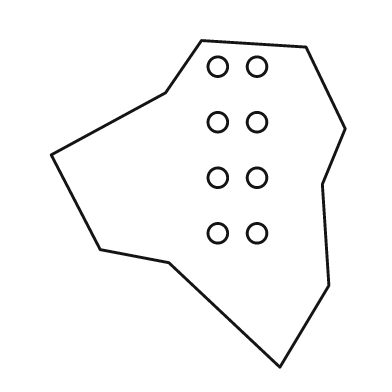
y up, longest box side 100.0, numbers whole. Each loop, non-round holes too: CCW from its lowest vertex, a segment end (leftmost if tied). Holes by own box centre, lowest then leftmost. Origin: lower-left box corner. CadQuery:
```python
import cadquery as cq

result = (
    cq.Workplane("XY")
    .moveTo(70.0, 0.0)
    .lineTo(85.0, 25.0)
    .lineTo(83.0, 56.0)
    .lineTo(90.0, 73.0)
    .lineTo(78.0, 98.0)
    .lineTo(46.0, 100.0)
    .lineTo(35.0, 84.0)
    .lineTo(0.0, 65.0)
    .lineTo(15.0, 36.0)
    .lineTo(36.0, 32.0)
    .close()
    .moveTo(51.0, 41.0)
    .circle(3.0)
    .moveTo(63.0, 41.0)
    .circle(3.0)
    .moveTo(51.0, 58.0)
    .circle(3.0)
    .moveTo(63.0, 58.0)
    .circle(3.0)
    .moveTo(51.0, 75.0)
    .circle(3.0)
    .moveTo(63.0, 75.0)
    .circle(3.0)
    .moveTo(51.0, 92.0)
    .circle(3.0)
    .moveTo(63.0, 92.0)
    .circle(3.0)
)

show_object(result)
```